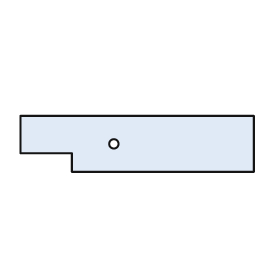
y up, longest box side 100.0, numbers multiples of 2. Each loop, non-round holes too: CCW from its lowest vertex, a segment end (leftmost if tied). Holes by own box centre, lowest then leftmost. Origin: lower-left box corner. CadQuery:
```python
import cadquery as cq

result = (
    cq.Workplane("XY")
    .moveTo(22.0, 0.0)
    .lineTo(100.0, 0.0)
    .lineTo(100.0, 24.0)
    .lineTo(0.0, 24.0)
    .lineTo(0.0, 8.0)
    .lineTo(22.0, 8.0)
    .close()
    .moveTo(40.0, 12.0)
    .circle(2.0)
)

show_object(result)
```